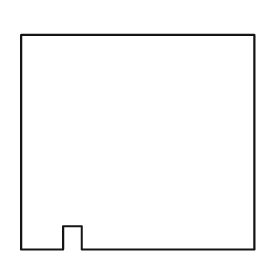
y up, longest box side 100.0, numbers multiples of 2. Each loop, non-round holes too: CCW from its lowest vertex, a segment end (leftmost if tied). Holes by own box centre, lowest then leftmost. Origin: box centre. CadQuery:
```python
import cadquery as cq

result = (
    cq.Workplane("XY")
    .moveTo(-50.0, -46.0)
    .lineTo(-32.0, -46.0)
    .lineTo(-32.0, -36.0)
    .lineTo(-24.0, -36.0)
    .lineTo(-24.0, -46.0)
    .lineTo(50.0, -46.0)
    .lineTo(50.0, 46.0)
    .lineTo(-50.0, 46.0)
    .close()
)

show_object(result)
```